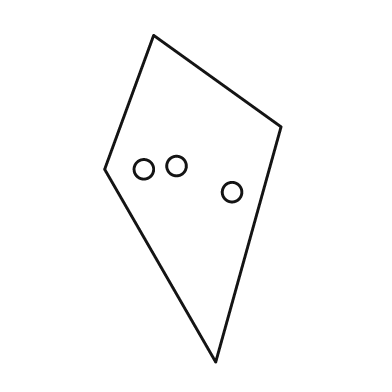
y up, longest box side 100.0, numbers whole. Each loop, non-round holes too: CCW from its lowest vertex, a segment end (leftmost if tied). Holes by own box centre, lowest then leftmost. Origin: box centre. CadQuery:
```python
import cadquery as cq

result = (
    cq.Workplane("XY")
    .moveTo(7.0, -50.0)
    .lineTo(27.0, 22.0)
    .lineTo(-12.0, 50.0)
    .lineTo(-27.0, 9.0)
    .close()
    .moveTo(12.0, 2.0)
    .circle(3.0)
    .moveTo(-15.0, 9.0)
    .circle(3.0)
    .moveTo(-5.0, 10.0)
    .circle(3.0)
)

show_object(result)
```